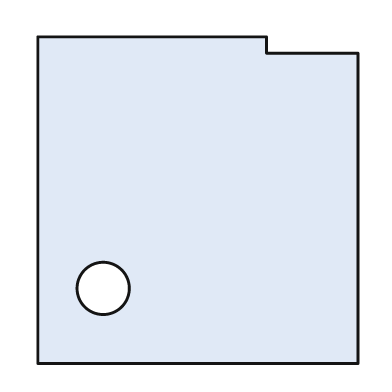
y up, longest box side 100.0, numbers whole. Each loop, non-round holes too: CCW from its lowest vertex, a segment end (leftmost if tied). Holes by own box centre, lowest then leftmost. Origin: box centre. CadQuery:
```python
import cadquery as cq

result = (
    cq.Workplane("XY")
    .moveTo(-49.0, -50.0)
    .lineTo(49.0, -50.0)
    .lineTo(49.0, 45.0)
    .lineTo(21.0, 45.0)
    .lineTo(21.0, 50.0)
    .lineTo(-49.0, 50.0)
    .close()
    .moveTo(-29.0, -27.0)
    .circle(8.0)
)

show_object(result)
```